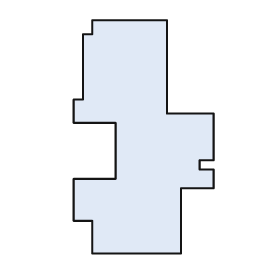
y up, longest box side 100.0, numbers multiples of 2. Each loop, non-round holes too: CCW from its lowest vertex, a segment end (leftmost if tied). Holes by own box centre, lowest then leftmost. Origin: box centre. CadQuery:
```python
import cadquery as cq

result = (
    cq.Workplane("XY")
    .moveTo(-22.0, -50.0)
    .lineTo(16.0, -50.0)
    .lineTo(16.0, -22.0)
    .lineTo(30.0, -22.0)
    .lineTo(30.0, -14.0)
    .lineTo(24.0, -14.0)
    .lineTo(24.0, -10.0)
    .lineTo(30.0, -10.0)
    .lineTo(30.0, 10.0)
    .lineTo(10.0, 10.0)
    .lineTo(10.0, 50.0)
    .lineTo(-22.0, 50.0)
    .lineTo(-22.0, 44.0)
    .lineTo(-26.0, 44.0)
    .lineTo(-26.0, 16.0)
    .lineTo(-30.0, 16.0)
    .lineTo(-30.0, 6.0)
    .lineTo(-12.0, 6.0)
    .lineTo(-12.0, -18.0)
    .lineTo(-30.0, -18.0)
    .lineTo(-30.0, -36.0)
    .lineTo(-22.0, -36.0)
    .close()
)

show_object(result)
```